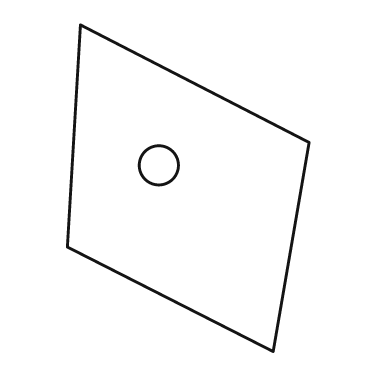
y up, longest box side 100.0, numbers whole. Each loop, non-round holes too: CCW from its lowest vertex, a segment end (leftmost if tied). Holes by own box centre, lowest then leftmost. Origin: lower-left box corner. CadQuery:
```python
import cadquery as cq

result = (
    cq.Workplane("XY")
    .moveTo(63.0, 0.0)
    .lineTo(74.0, 64.0)
    .lineTo(4.0, 100.0)
    .lineTo(0.0, 32.0)
    .close()
    .moveTo(28.0, 57.0)
    .circle(6.0)
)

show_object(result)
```